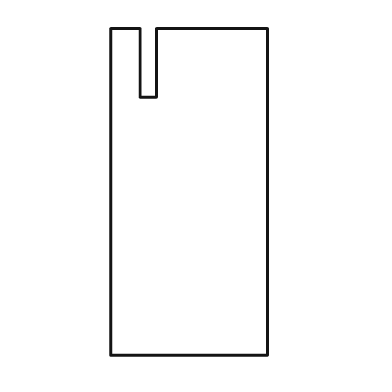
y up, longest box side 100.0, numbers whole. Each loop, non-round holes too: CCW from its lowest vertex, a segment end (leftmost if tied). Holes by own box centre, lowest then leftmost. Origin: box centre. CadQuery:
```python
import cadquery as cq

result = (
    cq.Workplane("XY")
    .moveTo(-24.0, -50.0)
    .lineTo(24.0, -50.0)
    .lineTo(24.0, 50.0)
    .lineTo(-10.0, 50.0)
    .lineTo(-10.0, 29.0)
    .lineTo(-15.0, 29.0)
    .lineTo(-15.0, 50.0)
    .lineTo(-24.0, 50.0)
    .close()
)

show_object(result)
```